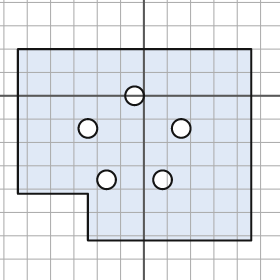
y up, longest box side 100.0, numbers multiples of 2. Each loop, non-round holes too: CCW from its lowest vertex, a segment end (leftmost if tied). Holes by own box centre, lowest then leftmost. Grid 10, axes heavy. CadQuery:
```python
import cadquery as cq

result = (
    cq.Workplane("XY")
    .moveTo(-24.0, -62.0)
    .lineTo(46.0, -62.0)
    .lineTo(46.0, 20.0)
    .lineTo(-54.0, 20.0)
    .lineTo(-54.0, -42.0)
    .lineTo(-24.0, -42.0)
    .close()
    .moveTo(-16.0, -36.0)
    .circle(4.0)
    .moveTo(8.0, -36.0)
    .circle(4.0)
    .moveTo(-24.0, -14.0)
    .circle(4.0)
    .moveTo(16.0, -14.0)
    .circle(4.0)
    .moveTo(-4.0, 0.0)
    .circle(4.0)
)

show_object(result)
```